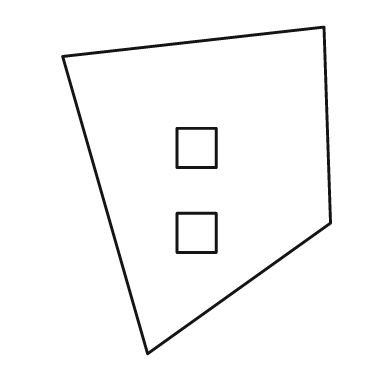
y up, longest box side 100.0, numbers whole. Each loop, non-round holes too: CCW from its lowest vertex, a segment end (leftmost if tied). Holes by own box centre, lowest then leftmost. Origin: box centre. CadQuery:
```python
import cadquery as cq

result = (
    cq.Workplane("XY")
    .moveTo(-15.0, -50.0)
    .lineTo(41.0, -10.0)
    .lineTo(39.0, 50.0)
    .lineTo(-41.0, 41.0)
    .close()
    .moveTo(-6.0, -19.0)
    .lineTo(6.0, -19.0)
    .lineTo(6.0, -7.0)
    .lineTo(-6.0, -7.0)
    .close()
    .moveTo(-6.0, 7.0)
    .lineTo(6.0, 7.0)
    .lineTo(6.0, 19.0)
    .lineTo(-6.0, 19.0)
    .close()
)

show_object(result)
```